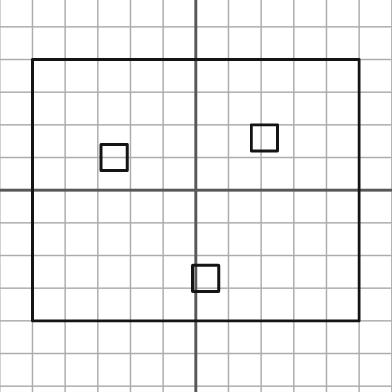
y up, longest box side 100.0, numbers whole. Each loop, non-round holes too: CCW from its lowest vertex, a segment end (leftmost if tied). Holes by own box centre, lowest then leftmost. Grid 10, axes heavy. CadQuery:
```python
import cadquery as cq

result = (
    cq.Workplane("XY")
    .moveTo(-50.0, -40.0)
    .lineTo(50.0, -40.0)
    .lineTo(50.0, 40.0)
    .lineTo(-50.0, 40.0)
    .close()
    .moveTo(-1.0, -31.0)
    .lineTo(7.0, -31.0)
    .lineTo(7.0, -23.0)
    .lineTo(-1.0, -23.0)
    .close()
    .moveTo(-29.0, 6.0)
    .lineTo(-21.0, 6.0)
    .lineTo(-21.0, 14.0)
    .lineTo(-29.0, 14.0)
    .close()
    .moveTo(17.0, 12.0)
    .lineTo(25.0, 12.0)
    .lineTo(25.0, 20.0)
    .lineTo(17.0, 20.0)
    .close()
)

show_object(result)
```